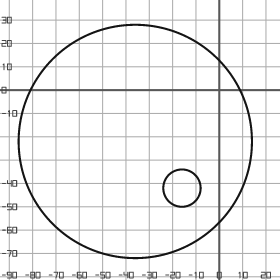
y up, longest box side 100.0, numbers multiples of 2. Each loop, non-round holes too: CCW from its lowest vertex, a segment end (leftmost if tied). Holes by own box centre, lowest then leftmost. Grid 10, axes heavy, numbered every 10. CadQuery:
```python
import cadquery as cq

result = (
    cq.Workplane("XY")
    .moveTo(-36.0, -22.0)
    .circle(50.0)
    .moveTo(-16.0, -42.0)
    .circle(8.0)
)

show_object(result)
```